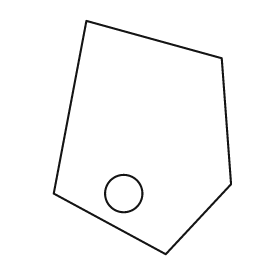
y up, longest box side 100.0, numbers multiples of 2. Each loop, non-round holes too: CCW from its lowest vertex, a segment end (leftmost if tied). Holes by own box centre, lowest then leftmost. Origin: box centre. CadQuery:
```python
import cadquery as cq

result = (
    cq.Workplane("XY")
    .moveTo(10.0, -50.0)
    .lineTo(38.0, -20.0)
    .lineTo(34.0, 34.0)
    .lineTo(-24.0, 50.0)
    .lineTo(-38.0, -24.0)
    .close()
    .moveTo(-8.0, -24.0)
    .circle(8.0)
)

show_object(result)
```